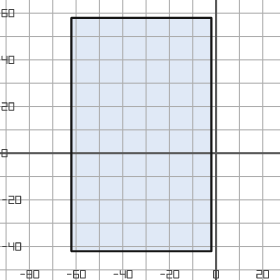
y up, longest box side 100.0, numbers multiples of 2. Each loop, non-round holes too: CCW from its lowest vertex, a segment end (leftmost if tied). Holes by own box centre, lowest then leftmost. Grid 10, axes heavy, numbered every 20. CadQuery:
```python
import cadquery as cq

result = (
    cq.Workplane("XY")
    .moveTo(-62.0, -42.0)
    .lineTo(-2.0, -42.0)
    .lineTo(-2.0, 58.0)
    .lineTo(-62.0, 58.0)
    .close()
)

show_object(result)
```